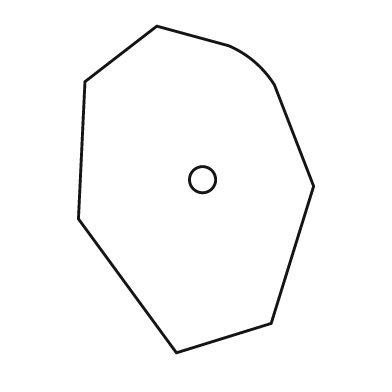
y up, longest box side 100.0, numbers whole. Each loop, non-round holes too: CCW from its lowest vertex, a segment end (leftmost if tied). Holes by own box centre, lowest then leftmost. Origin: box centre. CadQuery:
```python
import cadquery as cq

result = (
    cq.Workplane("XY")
    .moveTo(-6.0, -50.0)
    .lineTo(23.0, -41.0)
    .lineTo(36.0, 1.0)
    .lineTo(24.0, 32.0)
    .threePointArc((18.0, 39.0), (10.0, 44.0))
    .lineTo(-12.0, 50.0)
    .lineTo(-34.0, 33.0)
    .lineTo(-36.0, -9.0)
    .close()
    .moveTo(2.0, 3.0)
    .circle(4.0)
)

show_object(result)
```